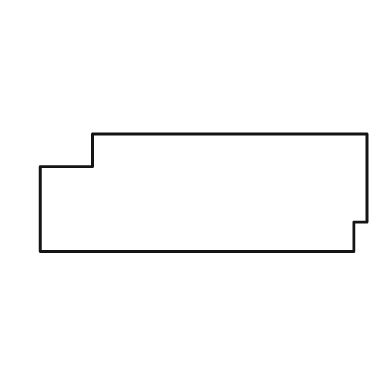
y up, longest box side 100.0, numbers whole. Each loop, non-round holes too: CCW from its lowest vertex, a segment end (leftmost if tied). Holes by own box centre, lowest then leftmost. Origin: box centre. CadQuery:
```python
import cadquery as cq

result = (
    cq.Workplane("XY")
    .moveTo(-50.0, -18.0)
    .lineTo(46.0, -18.0)
    .lineTo(46.0, -9.0)
    .lineTo(50.0, -9.0)
    .lineTo(50.0, 18.0)
    .lineTo(-34.0, 18.0)
    .lineTo(-34.0, 8.0)
    .lineTo(-50.0, 8.0)
    .close()
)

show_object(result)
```